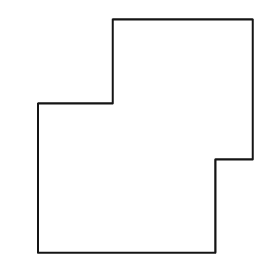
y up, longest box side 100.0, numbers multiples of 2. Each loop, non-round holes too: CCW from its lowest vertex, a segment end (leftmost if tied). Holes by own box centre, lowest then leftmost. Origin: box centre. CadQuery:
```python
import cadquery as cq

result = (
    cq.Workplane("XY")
    .moveTo(-46.0, -50.0)
    .lineTo(30.0, -50.0)
    .lineTo(30.0, -10.0)
    .lineTo(46.0, -10.0)
    .lineTo(46.0, 50.0)
    .lineTo(-14.0, 50.0)
    .lineTo(-14.0, 14.0)
    .lineTo(-46.0, 14.0)
    .close()
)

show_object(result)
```